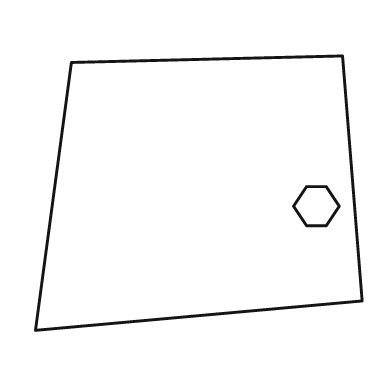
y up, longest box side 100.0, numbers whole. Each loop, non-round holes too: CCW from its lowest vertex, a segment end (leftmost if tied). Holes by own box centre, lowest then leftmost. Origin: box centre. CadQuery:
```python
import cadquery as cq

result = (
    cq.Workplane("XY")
    .moveTo(-50.0, -42.0)
    .lineTo(50.0, -33.0)
    .lineTo(44.0, 42.0)
    .lineTo(-39.0, 40.0)
    .close()
    .moveTo(33.0, -10.0)
    .lineTo(39.0, -10.0)
    .lineTo(43.0, -4.0)
    .lineTo(39.0, 2.0)
    .lineTo(33.0, 2.0)
    .lineTo(29.0, -4.0)
    .close()
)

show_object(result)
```